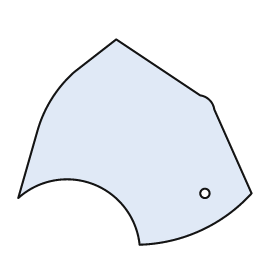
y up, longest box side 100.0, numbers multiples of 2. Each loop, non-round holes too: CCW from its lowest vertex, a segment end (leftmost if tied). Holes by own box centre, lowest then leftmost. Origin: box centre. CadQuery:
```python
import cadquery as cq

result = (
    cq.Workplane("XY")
    .moveTo(2.0, -44.0)
    .threePointArc((28.0, -38.0), (50.0, -22.0))
    .lineTo(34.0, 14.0)
    .threePointArc((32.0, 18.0), (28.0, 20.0))
    .lineTo(-8.0, 44.0)
    .lineTo(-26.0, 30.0)
    .threePointArc((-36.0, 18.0), (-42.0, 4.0))
    .lineTo(-50.0, -24.0)
    .threePointArc((-18.0, -18.0), (2.0, -44.0))
    .close()
    .moveTo(30.0, -22.0)
    .circle(2.0)
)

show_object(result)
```